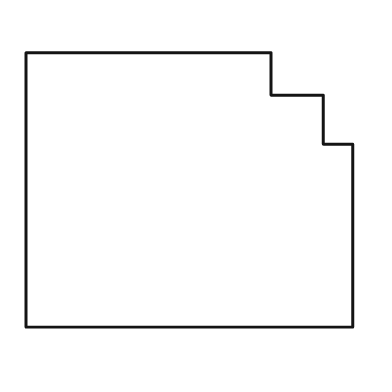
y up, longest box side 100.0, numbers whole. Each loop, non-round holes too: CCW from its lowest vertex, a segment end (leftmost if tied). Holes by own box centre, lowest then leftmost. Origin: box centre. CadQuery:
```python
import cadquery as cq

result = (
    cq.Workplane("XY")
    .moveTo(-50.0, -42.0)
    .lineTo(50.0, -42.0)
    .lineTo(50.0, 14.0)
    .lineTo(41.0, 14.0)
    .lineTo(41.0, 29.0)
    .lineTo(25.0, 29.0)
    .lineTo(25.0, 42.0)
    .lineTo(-50.0, 42.0)
    .close()
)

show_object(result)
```